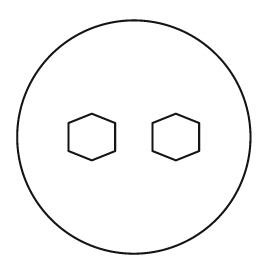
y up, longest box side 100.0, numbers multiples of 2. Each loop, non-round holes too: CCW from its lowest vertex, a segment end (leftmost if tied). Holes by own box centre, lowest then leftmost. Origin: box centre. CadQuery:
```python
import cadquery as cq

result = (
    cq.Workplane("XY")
    .moveTo(0.0, 0.0)
    .circle(50.0)
    .moveTo(-18.0, -10.0)
    .lineTo(-8.0, -6.0)
    .lineTo(-8.0, 6.0)
    .lineTo(-18.0, 10.0)
    .lineTo(-28.0, 6.0)
    .lineTo(-28.0, -6.0)
    .close()
    .moveTo(18.0, -10.0)
    .lineTo(28.0, -6.0)
    .lineTo(28.0, 6.0)
    .lineTo(18.0, 10.0)
    .lineTo(8.0, 6.0)
    .lineTo(8.0, -6.0)
    .close()
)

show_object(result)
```